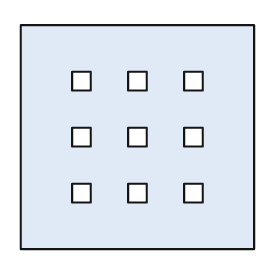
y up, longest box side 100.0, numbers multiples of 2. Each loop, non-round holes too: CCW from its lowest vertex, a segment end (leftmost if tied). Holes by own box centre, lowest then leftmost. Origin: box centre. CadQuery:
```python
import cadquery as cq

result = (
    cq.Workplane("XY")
    .moveTo(-50.0, -48.0)
    .lineTo(50.0, -48.0)
    .lineTo(50.0, 48.0)
    .lineTo(-50.0, 48.0)
    .close()
    .moveTo(-28.0, -28.0)
    .lineTo(-20.0, -28.0)
    .lineTo(-20.0, -20.0)
    .lineTo(-28.0, -20.0)
    .close()
    .moveTo(-4.0, -28.0)
    .lineTo(4.0, -28.0)
    .lineTo(4.0, -20.0)
    .lineTo(-4.0, -20.0)
    .close()
    .moveTo(20.0, -28.0)
    .lineTo(28.0, -28.0)
    .lineTo(28.0, -20.0)
    .lineTo(20.0, -20.0)
    .close()
    .moveTo(-28.0, -4.0)
    .lineTo(-20.0, -4.0)
    .lineTo(-20.0, 4.0)
    .lineTo(-28.0, 4.0)
    .close()
    .moveTo(-4.0, -4.0)
    .lineTo(4.0, -4.0)
    .lineTo(4.0, 4.0)
    .lineTo(-4.0, 4.0)
    .close()
    .moveTo(20.0, -4.0)
    .lineTo(28.0, -4.0)
    .lineTo(28.0, 4.0)
    .lineTo(20.0, 4.0)
    .close()
    .moveTo(-28.0, 20.0)
    .lineTo(-20.0, 20.0)
    .lineTo(-20.0, 28.0)
    .lineTo(-28.0, 28.0)
    .close()
    .moveTo(-4.0, 20.0)
    .lineTo(4.0, 20.0)
    .lineTo(4.0, 28.0)
    .lineTo(-4.0, 28.0)
    .close()
    .moveTo(20.0, 20.0)
    .lineTo(28.0, 20.0)
    .lineTo(28.0, 28.0)
    .lineTo(20.0, 28.0)
    .close()
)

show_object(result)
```